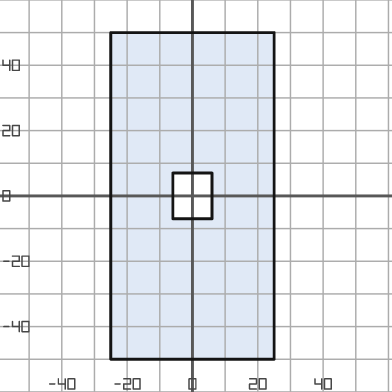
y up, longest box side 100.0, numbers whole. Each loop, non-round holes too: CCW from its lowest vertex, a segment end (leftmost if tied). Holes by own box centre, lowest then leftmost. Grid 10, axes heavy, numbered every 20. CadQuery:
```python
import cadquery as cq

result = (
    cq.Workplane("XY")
    .moveTo(-25.0, -50.0)
    .lineTo(25.0, -50.0)
    .lineTo(25.0, 50.0)
    .lineTo(-25.0, 50.0)
    .close()
    .moveTo(-6.0, -7.0)
    .lineTo(6.0, -7.0)
    .lineTo(6.0, 7.0)
    .lineTo(-6.0, 7.0)
    .close()
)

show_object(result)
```